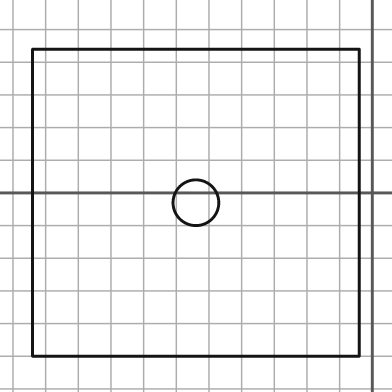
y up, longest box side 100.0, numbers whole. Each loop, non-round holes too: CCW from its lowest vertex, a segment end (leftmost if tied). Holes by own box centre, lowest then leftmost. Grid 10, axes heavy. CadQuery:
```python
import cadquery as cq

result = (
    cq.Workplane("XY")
    .moveTo(-104.0, -50.0)
    .lineTo(-4.0, -50.0)
    .lineTo(-4.0, 44.0)
    .lineTo(-104.0, 44.0)
    .close()
    .moveTo(-54.0, -3.0)
    .circle(7.0)
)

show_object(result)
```